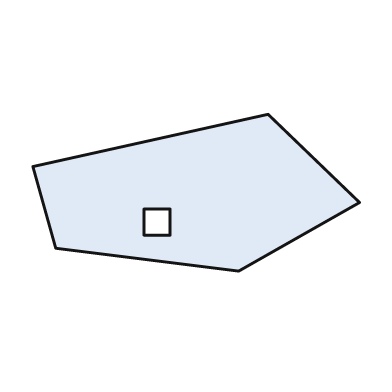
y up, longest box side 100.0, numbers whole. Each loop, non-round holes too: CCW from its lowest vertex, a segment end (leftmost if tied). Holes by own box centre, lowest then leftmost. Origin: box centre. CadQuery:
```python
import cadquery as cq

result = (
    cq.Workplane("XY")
    .moveTo(13.0, -24.0)
    .lineTo(50.0, -3.0)
    .lineTo(22.0, 24.0)
    .lineTo(-50.0, 8.0)
    .lineTo(-43.0, -17.0)
    .close()
    .moveTo(-16.0, -13.0)
    .lineTo(-8.0, -13.0)
    .lineTo(-8.0, -5.0)
    .lineTo(-16.0, -5.0)
    .close()
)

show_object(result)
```